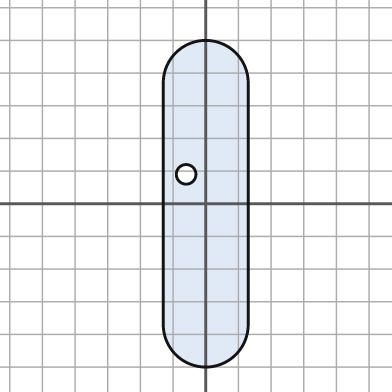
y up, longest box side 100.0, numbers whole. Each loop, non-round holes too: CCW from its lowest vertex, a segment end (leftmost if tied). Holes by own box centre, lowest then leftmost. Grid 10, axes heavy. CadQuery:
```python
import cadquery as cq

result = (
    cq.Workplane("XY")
    .moveTo(-13.0, -37.0)
    .threePointArc((0.0, -50.0), (13.0, -37.0))
    .lineTo(13.0, 37.0)
    .threePointArc((0.0, 50.0), (-13.0, 37.0))
    .close()
    .moveTo(-6.0, 9.0)
    .circle(3.0)
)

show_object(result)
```